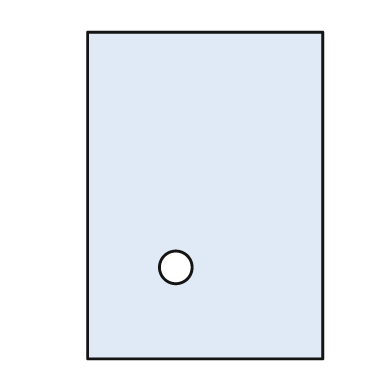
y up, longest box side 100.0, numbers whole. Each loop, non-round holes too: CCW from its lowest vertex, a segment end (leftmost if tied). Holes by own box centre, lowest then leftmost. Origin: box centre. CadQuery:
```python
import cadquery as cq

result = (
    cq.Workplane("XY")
    .moveTo(-36.0, -50.0)
    .lineTo(36.0, -50.0)
    .lineTo(36.0, 50.0)
    .lineTo(-36.0, 50.0)
    .close()
    .moveTo(-9.0, -22.0)
    .circle(5.0)
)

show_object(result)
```